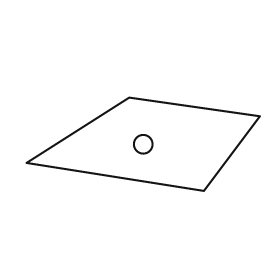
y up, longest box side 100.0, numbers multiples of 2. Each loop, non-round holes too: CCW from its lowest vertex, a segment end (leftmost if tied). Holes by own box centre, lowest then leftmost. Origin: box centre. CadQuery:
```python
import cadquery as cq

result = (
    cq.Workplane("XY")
    .moveTo(26.0, -20.0)
    .lineTo(50.0, 12.0)
    .lineTo(-6.0, 20.0)
    .lineTo(-50.0, -8.0)
    .close()
    .moveTo(0.0, 0.0)
    .circle(4.0)
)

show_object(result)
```